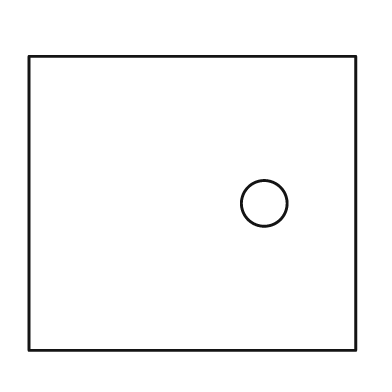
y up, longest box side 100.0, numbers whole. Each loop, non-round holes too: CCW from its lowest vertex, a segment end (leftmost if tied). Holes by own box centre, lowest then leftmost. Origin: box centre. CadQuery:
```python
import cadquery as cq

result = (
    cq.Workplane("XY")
    .moveTo(-50.0, -45.0)
    .lineTo(50.0, -45.0)
    .lineTo(50.0, 45.0)
    .lineTo(-50.0, 45.0)
    .close()
    .moveTo(22.0, 0.0)
    .circle(7.0)
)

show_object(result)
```